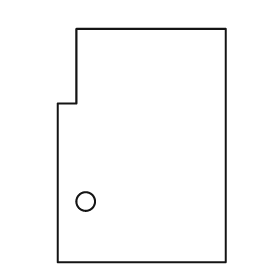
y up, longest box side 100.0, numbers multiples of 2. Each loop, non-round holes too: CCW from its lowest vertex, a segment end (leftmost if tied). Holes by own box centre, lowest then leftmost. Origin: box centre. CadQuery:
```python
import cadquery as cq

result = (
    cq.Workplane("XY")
    .moveTo(-36.0, -50.0)
    .lineTo(36.0, -50.0)
    .lineTo(36.0, 50.0)
    .lineTo(-28.0, 50.0)
    .lineTo(-28.0, 18.0)
    .lineTo(-36.0, 18.0)
    .close()
    .moveTo(-24.0, -24.0)
    .circle(4.0)
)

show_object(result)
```